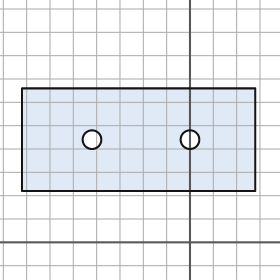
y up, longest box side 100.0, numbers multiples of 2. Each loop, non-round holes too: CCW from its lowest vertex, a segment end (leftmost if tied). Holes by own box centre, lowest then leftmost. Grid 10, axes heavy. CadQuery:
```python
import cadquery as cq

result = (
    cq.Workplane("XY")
    .moveTo(-72.0, 22.0)
    .lineTo(28.0, 22.0)
    .lineTo(28.0, 66.0)
    .lineTo(-72.0, 66.0)
    .close()
    .moveTo(-42.0, 44.0)
    .circle(4.0)
    .moveTo(0.0, 44.0)
    .circle(4.0)
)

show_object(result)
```